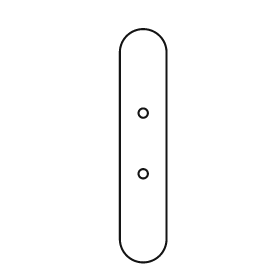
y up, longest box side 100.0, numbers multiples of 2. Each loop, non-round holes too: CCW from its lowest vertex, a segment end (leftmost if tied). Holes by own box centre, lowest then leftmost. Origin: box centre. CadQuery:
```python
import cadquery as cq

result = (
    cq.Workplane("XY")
    .moveTo(-10.0, -40.0)
    .threePointArc((0.0, -50.0), (10.0, -40.0))
    .lineTo(10.0, 40.0)
    .threePointArc((0.0, 50.0), (-10.0, 40.0))
    .close()
    .moveTo(0.0, -12.0)
    .circle(2.0)
    .moveTo(0.0, 14.0)
    .circle(2.0)
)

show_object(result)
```